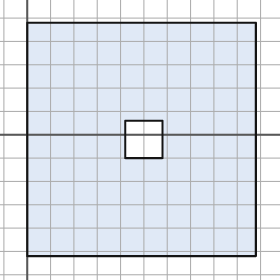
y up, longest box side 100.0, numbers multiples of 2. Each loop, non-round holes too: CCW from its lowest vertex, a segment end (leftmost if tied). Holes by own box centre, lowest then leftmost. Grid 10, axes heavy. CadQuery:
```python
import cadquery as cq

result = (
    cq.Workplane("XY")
    .moveTo(0.0, -52.0)
    .lineTo(98.0, -52.0)
    .lineTo(98.0, 48.0)
    .lineTo(0.0, 48.0)
    .close()
    .moveTo(42.0, -10.0)
    .lineTo(58.0, -10.0)
    .lineTo(58.0, 6.0)
    .lineTo(42.0, 6.0)
    .close()
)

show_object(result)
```